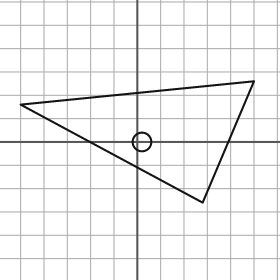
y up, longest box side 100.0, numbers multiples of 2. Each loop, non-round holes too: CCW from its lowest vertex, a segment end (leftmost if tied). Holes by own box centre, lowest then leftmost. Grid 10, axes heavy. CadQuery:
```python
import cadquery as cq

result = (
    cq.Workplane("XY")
    .moveTo(28.0, -26.0)
    .lineTo(50.0, 26.0)
    .lineTo(-50.0, 16.0)
    .close()
    .moveTo(2.0, 0.0)
    .circle(4.0)
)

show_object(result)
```